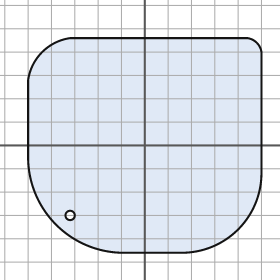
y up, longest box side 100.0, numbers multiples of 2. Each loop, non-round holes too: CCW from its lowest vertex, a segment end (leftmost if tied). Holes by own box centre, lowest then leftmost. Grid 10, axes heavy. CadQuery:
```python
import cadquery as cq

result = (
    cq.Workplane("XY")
    .moveTo(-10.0, -46.0)
    .lineTo(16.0, -46.0)
    .threePointArc((40.0, -36.0), (50.0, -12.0))
    .lineTo(50.0, 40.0)
    .threePointArc((48.0, 44.0), (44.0, 46.0))
    .lineTo(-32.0, 46.0)
    .threePointArc((-44.0, 40.0), (-50.0, 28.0))
    .lineTo(-50.0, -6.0)
    .threePointArc((-38.0, -34.0), (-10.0, -46.0))
    .close()
    .moveTo(-32.0, -30.0)
    .circle(2.0)
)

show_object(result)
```